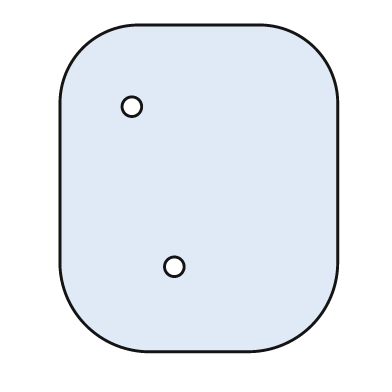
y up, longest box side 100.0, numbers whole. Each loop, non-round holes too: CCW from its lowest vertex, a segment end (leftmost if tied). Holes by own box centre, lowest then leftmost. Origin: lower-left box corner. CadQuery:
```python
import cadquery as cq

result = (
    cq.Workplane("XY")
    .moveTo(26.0, 0.0)
    .lineTo(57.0, 0.0)
    .threePointArc((77.0, 8.0), (85.0, 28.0))
    .lineTo(85.0, 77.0)
    .threePointArc((78.0, 93.0), (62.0, 100.0))
    .lineTo(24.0, 100.0)
    .threePointArc((7.0, 93.0), (0.0, 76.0))
    .lineTo(0.0, 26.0)
    .threePointArc((8.0, 8.0), (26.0, 0.0))
    .close()
    .moveTo(35.0, 26.0)
    .circle(3.0)
    .moveTo(22.0, 75.0)
    .circle(3.0)
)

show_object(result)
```